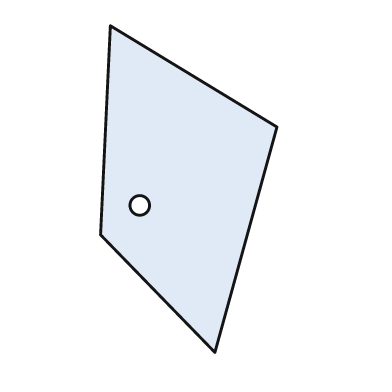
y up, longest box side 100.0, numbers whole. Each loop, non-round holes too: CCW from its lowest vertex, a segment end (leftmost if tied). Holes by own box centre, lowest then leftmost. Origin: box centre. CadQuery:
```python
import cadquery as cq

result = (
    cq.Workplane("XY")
    .moveTo(8.0, -50.0)
    .lineTo(27.0, 19.0)
    .lineTo(-24.0, 50.0)
    .lineTo(-27.0, -14.0)
    .close()
    .moveTo(-15.0, -5.0)
    .circle(3.0)
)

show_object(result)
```